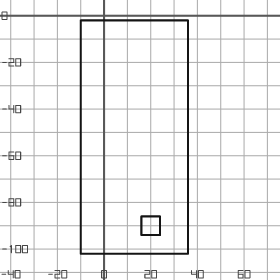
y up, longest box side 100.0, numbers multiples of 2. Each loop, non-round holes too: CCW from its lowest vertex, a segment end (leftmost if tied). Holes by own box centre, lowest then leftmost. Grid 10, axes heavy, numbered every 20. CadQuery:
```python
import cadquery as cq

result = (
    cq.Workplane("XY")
    .moveTo(-10.0, -102.0)
    .lineTo(36.0, -102.0)
    .lineTo(36.0, -2.0)
    .lineTo(-10.0, -2.0)
    .close()
    .moveTo(16.0, -94.0)
    .lineTo(24.0, -94.0)
    .lineTo(24.0, -86.0)
    .lineTo(16.0, -86.0)
    .close()
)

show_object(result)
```